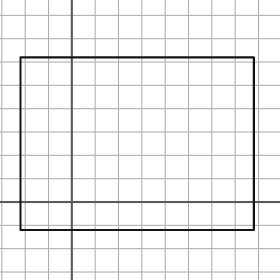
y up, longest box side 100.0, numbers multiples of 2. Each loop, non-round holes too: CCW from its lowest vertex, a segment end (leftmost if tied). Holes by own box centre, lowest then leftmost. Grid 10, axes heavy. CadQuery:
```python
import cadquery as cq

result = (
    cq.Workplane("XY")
    .moveTo(-22.0, -12.0)
    .lineTo(78.0, -12.0)
    .lineTo(78.0, 62.0)
    .lineTo(-22.0, 62.0)
    .close()
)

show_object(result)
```